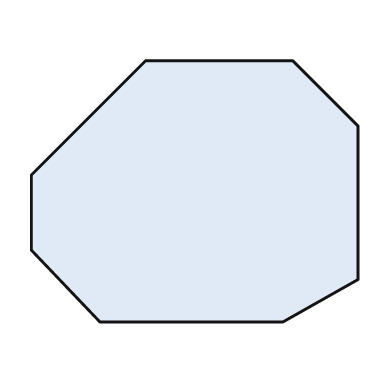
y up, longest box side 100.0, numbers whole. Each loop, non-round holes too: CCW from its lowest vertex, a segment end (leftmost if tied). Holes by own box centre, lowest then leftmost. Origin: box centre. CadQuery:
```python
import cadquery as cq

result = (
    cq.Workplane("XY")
    .moveTo(-29.0, -40.0)
    .lineTo(27.0, -40.0)
    .lineTo(50.0, -27.0)
    .lineTo(50.0, 20.0)
    .lineTo(30.0, 40.0)
    .lineTo(-15.0, 40.0)
    .lineTo(-50.0, 5.0)
    .lineTo(-50.0, -18.0)
    .close()
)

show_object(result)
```